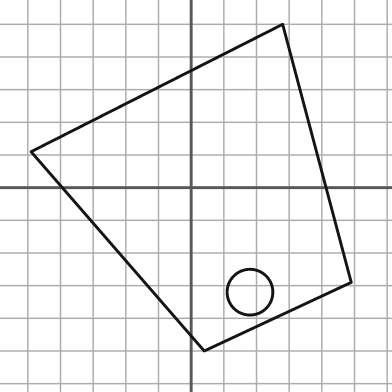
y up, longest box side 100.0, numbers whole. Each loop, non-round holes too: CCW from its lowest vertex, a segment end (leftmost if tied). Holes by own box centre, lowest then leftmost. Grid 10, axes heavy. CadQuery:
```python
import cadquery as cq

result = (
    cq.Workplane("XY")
    .moveTo(4.0, -50.0)
    .lineTo(49.0, -29.0)
    .lineTo(28.0, 50.0)
    .lineTo(-49.0, 11.0)
    .close()
    .moveTo(18.0, -32.0)
    .circle(7.0)
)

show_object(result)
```